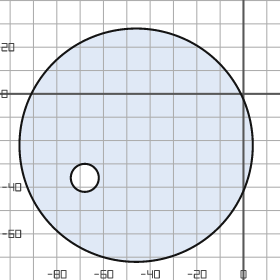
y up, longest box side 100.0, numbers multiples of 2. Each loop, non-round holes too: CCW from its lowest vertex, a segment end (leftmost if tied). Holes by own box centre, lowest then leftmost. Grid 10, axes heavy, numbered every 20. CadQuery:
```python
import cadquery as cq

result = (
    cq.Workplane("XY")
    .moveTo(-46.0, -22.0)
    .circle(50.0)
    .moveTo(-68.0, -36.0)
    .circle(6.0)
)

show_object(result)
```